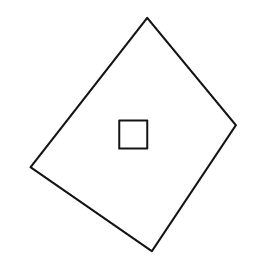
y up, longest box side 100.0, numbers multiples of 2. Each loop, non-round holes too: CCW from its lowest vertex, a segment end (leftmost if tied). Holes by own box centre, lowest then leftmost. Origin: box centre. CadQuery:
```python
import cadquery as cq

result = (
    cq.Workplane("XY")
    .moveTo(8.0, -50.0)
    .lineTo(44.0, 4.0)
    .lineTo(6.0, 50.0)
    .lineTo(-44.0, -14.0)
    .close()
    .moveTo(-6.0, -6.0)
    .lineTo(6.0, -6.0)
    .lineTo(6.0, 6.0)
    .lineTo(-6.0, 6.0)
    .close()
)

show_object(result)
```